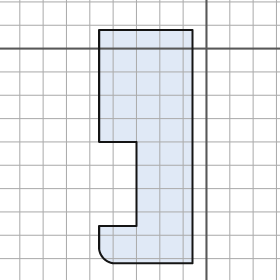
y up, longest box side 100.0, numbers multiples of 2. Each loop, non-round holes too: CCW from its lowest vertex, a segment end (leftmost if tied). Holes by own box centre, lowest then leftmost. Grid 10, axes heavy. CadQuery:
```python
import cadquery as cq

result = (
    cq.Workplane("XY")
    .moveTo(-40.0, -92.0)
    .lineTo(-6.0, -92.0)
    .lineTo(-6.0, 8.0)
    .lineTo(-46.0, 8.0)
    .lineTo(-46.0, -40.0)
    .lineTo(-30.0, -40.0)
    .lineTo(-30.0, -76.0)
    .lineTo(-46.0, -76.0)
    .lineTo(-46.0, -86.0)
    .threePointArc((-44.0, -90.0), (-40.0, -92.0))
    .close()
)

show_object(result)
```